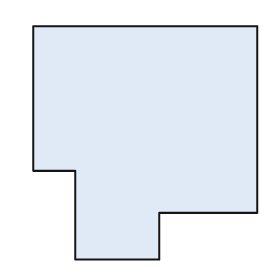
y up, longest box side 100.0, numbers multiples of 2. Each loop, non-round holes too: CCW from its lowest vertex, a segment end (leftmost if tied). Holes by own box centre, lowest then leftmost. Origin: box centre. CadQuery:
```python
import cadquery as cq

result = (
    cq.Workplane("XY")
    .moveTo(-30.0, -50.0)
    .lineTo(6.0, -50.0)
    .lineTo(6.0, -30.0)
    .lineTo(48.0, -30.0)
    .lineTo(48.0, 50.0)
    .lineTo(-48.0, 50.0)
    .lineTo(-48.0, -12.0)
    .lineTo(-30.0, -12.0)
    .close()
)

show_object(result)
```